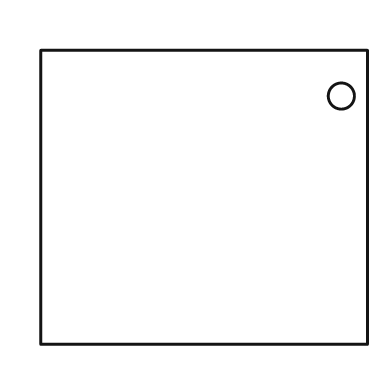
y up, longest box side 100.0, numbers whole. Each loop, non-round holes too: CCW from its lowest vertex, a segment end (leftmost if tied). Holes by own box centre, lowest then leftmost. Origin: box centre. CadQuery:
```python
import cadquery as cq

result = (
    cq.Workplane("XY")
    .moveTo(-50.0, -45.0)
    .lineTo(50.0, -45.0)
    .lineTo(50.0, 45.0)
    .lineTo(-50.0, 45.0)
    .close()
    .moveTo(42.0, 31.0)
    .circle(4.0)
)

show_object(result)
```